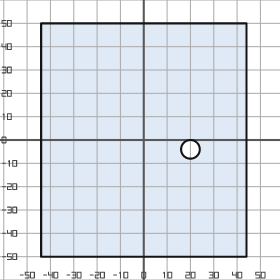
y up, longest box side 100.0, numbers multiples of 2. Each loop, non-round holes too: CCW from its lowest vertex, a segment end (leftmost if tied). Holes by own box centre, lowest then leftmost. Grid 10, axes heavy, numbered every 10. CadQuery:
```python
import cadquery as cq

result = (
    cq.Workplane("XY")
    .moveTo(-44.0, -50.0)
    .lineTo(44.0, -50.0)
    .lineTo(44.0, 50.0)
    .lineTo(-44.0, 50.0)
    .close()
    .moveTo(20.0, -4.0)
    .circle(4.0)
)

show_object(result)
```